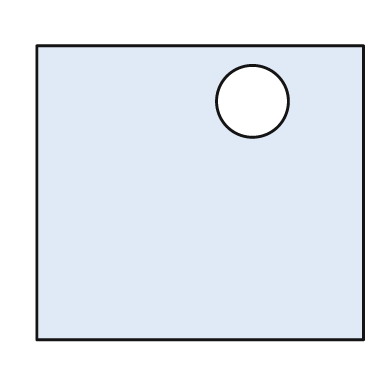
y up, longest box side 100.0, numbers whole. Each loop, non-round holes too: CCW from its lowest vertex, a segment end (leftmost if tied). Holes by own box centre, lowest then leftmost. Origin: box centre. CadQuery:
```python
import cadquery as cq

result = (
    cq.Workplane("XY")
    .moveTo(-50.0, -45.0)
    .lineTo(50.0, -45.0)
    .lineTo(50.0, 45.0)
    .lineTo(-50.0, 45.0)
    .close()
    .moveTo(16.0, 28.0)
    .circle(11.0)
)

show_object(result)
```